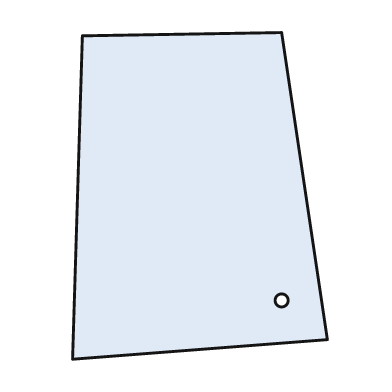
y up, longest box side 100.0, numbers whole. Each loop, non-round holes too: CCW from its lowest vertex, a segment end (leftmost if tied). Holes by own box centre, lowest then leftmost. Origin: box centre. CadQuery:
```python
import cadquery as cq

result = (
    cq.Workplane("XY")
    .moveTo(-39.0, -50.0)
    .lineTo(39.0, -44.0)
    .lineTo(25.0, 50.0)
    .lineTo(-36.0, 49.0)
    .close()
    .moveTo(25.0, -32.0)
    .circle(2.0)
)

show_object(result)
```